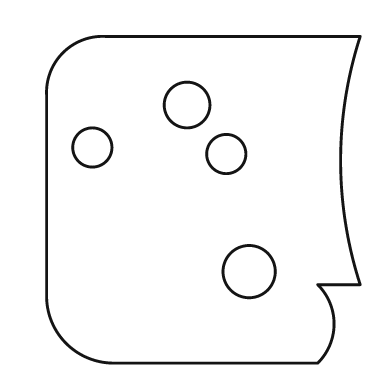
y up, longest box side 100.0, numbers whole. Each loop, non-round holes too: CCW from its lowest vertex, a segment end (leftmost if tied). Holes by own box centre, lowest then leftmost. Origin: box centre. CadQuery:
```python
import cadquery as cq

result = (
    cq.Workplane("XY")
    .moveTo(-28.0, -50.0)
    .lineTo(35.0, -50.0)
    .threePointArc((40.0, -38.0), (35.0, -26.0))
    .lineTo(48.0, -26.0)
    .threePointArc((42.0, 12.0), (48.0, 50.0))
    .lineTo(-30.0, 50.0)
    .threePointArc((-43.0, 45.0), (-48.0, 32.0))
    .lineTo(-48.0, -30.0)
    .threePointArc((-42.0, -44.0), (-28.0, -50.0))
    .close()
    .moveTo(14.0, -22.0)
    .circle(8.0)
    .moveTo(7.0, 14.0)
    .circle(6.0)
    .moveTo(-34.0, 16.0)
    .circle(6.0)
    .moveTo(-5.0, 29.0)
    .circle(7.0)
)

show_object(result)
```